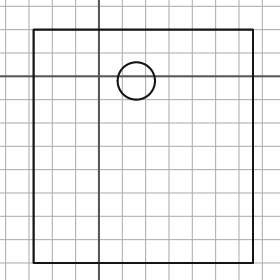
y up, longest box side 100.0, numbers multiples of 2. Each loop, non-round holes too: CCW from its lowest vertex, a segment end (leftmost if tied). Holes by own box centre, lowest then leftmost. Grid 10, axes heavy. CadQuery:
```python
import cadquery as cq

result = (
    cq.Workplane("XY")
    .moveTo(-28.0, -80.0)
    .lineTo(66.0, -80.0)
    .lineTo(66.0, 20.0)
    .lineTo(-28.0, 20.0)
    .close()
    .moveTo(16.0, -2.0)
    .circle(8.0)
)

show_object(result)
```